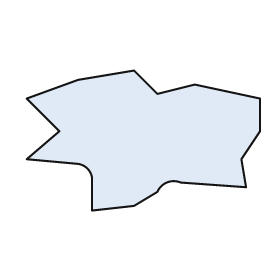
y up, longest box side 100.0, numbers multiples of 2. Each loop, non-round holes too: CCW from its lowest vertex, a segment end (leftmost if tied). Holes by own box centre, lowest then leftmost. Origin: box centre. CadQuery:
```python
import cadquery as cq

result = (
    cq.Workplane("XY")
    .moveTo(-22.0, -30.0)
    .lineTo(-4.0, -28.0)
    .lineTo(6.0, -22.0)
    .threePointArc((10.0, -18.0), (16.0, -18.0))
    .lineTo(44.0, -20.0)
    .lineTo(42.0, -8.0)
    .lineTo(50.0, 4.0)
    .lineTo(50.0, 18.0)
    .lineTo(22.0, 24.0)
    .lineTo(6.0, 20.0)
    .lineTo(-4.0, 30.0)
    .lineTo(-28.0, 26.0)
    .lineTo(-50.0, 18.0)
    .lineTo(-36.0, 4.0)
    .lineTo(-50.0, -8.0)
    .lineTo(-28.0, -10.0)
    .threePointArc((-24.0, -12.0), (-22.0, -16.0))
    .close()
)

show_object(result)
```